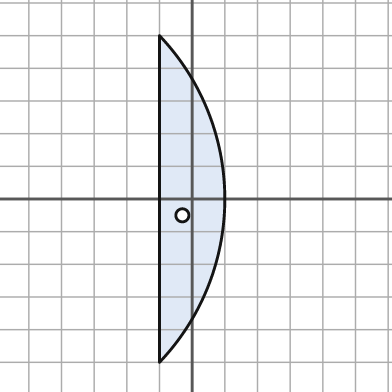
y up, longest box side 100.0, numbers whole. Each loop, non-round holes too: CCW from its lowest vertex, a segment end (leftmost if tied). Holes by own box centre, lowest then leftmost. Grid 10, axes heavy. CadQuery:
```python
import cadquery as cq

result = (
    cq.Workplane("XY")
    .moveTo(-10.0, -50.0)
    .threePointArc((10.0, 0.0), (-10.0, 50.0))
    .close()
    .moveTo(-3.0, -5.0)
    .circle(2.0)
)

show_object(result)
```